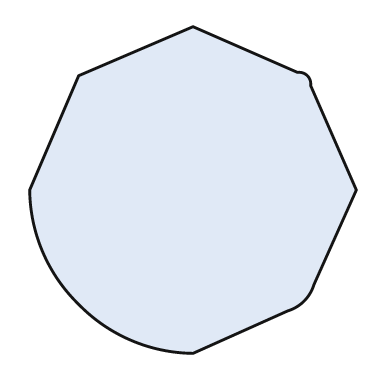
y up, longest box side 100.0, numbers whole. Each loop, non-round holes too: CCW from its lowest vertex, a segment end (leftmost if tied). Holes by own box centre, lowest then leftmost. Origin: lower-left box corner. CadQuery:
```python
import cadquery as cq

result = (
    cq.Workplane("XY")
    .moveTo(50.0, 0.0)
    .lineTo(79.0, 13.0)
    .threePointArc((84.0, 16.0), (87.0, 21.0))
    .lineTo(100.0, 50.0)
    .lineTo(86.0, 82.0)
    .threePointArc((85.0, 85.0), (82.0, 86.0))
    .lineTo(50.0, 100.0)
    .lineTo(15.0, 85.0)
    .lineTo(0.0, 50.0)
    .threePointArc((4.0, 31.0), (15.0, 15.0))
    .threePointArc((31.0, 4.0), (50.0, 0.0))
    .close()
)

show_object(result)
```